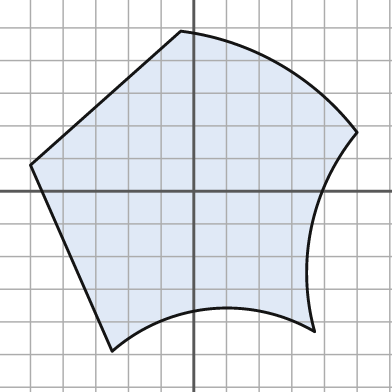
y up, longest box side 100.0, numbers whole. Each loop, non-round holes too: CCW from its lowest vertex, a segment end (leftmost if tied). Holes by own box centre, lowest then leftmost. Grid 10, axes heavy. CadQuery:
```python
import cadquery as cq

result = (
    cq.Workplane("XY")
    .moveTo(-25.0, -49.0)
    .threePointArc((5.0, -36.0), (37.0, -43.0))
    .threePointArc((36.0, -11.0), (50.0, 18.0))
    .threePointArc((26.0, 39.0), (-4.0, 49.0))
    .lineTo(-50.0, 8.0)
    .close()
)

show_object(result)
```